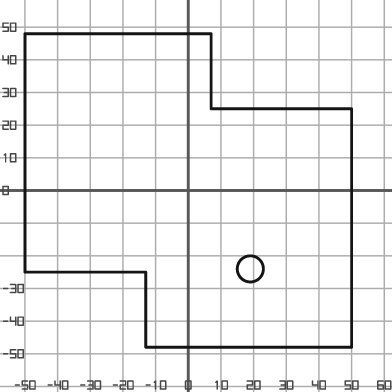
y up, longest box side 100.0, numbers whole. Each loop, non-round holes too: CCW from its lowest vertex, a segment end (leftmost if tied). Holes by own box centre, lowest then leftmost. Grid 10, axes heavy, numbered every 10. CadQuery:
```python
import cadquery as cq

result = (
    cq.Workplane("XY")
    .moveTo(-13.0, -48.0)
    .lineTo(50.0, -48.0)
    .lineTo(50.0, 25.0)
    .lineTo(7.0, 25.0)
    .lineTo(7.0, 48.0)
    .lineTo(-50.0, 48.0)
    .lineTo(-50.0, -25.0)
    .lineTo(-13.0, -25.0)
    .close()
    .moveTo(19.0, -24.0)
    .circle(4.0)
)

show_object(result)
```